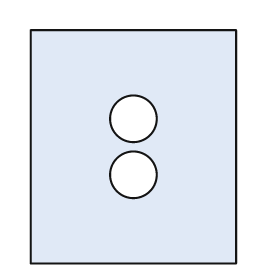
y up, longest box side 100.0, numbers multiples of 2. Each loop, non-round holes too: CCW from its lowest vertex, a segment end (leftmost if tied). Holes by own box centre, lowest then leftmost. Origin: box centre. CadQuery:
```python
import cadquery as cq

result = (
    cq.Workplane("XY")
    .moveTo(-44.0, -50.0)
    .lineTo(44.0, -50.0)
    .lineTo(44.0, 50.0)
    .lineTo(-44.0, 50.0)
    .close()
    .moveTo(0.0, -12.0)
    .circle(10.0)
    .moveTo(0.0, 12.0)
    .circle(10.0)
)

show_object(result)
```